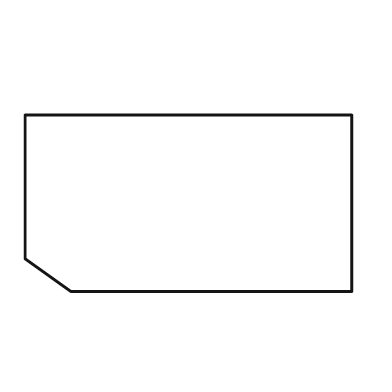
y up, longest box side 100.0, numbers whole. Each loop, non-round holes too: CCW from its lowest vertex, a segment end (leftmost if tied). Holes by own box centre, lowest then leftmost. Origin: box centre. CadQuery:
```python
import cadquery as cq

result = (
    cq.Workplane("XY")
    .moveTo(-36.0, -27.0)
    .lineTo(50.0, -27.0)
    .lineTo(50.0, 27.0)
    .lineTo(-50.0, 27.0)
    .lineTo(-50.0, -17.0)
    .close()
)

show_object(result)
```